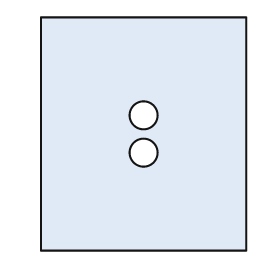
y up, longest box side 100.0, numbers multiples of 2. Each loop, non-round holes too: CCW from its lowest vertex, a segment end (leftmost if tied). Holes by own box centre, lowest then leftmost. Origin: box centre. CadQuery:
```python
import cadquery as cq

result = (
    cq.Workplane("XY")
    .moveTo(-44.0, -50.0)
    .lineTo(44.0, -50.0)
    .lineTo(44.0, 50.0)
    .lineTo(-44.0, 50.0)
    .close()
    .moveTo(0.0, -8.0)
    .circle(6.0)
    .moveTo(0.0, 8.0)
    .circle(6.0)
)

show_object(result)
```